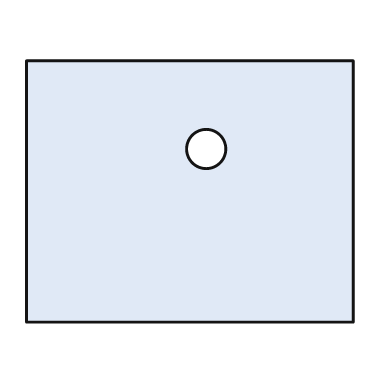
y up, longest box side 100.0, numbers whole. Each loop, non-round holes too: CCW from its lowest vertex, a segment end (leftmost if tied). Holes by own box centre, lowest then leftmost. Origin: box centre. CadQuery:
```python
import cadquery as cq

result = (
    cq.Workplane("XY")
    .moveTo(-50.0, -40.0)
    .lineTo(50.0, -40.0)
    .lineTo(50.0, 40.0)
    .lineTo(-50.0, 40.0)
    .close()
    .moveTo(5.0, 13.0)
    .circle(6.0)
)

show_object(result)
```